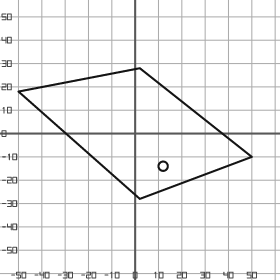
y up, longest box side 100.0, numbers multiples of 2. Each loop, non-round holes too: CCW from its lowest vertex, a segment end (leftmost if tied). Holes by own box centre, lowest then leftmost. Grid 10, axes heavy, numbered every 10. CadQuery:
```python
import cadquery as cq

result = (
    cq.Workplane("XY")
    .moveTo(2.0, -28.0)
    .lineTo(50.0, -10.0)
    .lineTo(2.0, 28.0)
    .lineTo(-50.0, 18.0)
    .close()
    .moveTo(12.0, -14.0)
    .circle(2.0)
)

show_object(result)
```